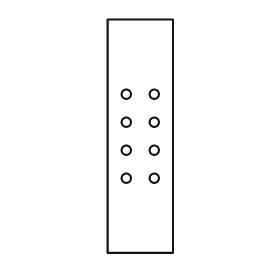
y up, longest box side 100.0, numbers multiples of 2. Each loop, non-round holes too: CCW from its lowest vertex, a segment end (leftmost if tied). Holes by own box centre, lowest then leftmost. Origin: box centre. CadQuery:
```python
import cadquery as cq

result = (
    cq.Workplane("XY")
    .moveTo(-14.0, -50.0)
    .lineTo(14.0, -50.0)
    .lineTo(14.0, 50.0)
    .lineTo(-14.0, 50.0)
    .close()
    .moveTo(-6.0, -18.0)
    .circle(2.0)
    .moveTo(6.0, -18.0)
    .circle(2.0)
    .moveTo(-6.0, -6.0)
    .circle(2.0)
    .moveTo(6.0, -6.0)
    .circle(2.0)
    .moveTo(-6.0, 6.0)
    .circle(2.0)
    .moveTo(6.0, 6.0)
    .circle(2.0)
    .moveTo(-6.0, 18.0)
    .circle(2.0)
    .moveTo(6.0, 18.0)
    .circle(2.0)
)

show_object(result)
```